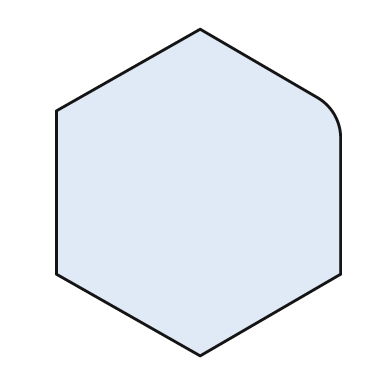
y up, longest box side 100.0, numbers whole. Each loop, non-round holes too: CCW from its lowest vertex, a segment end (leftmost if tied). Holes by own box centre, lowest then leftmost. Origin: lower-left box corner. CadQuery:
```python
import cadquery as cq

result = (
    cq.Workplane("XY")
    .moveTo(44.0, 0.0)
    .lineTo(87.0, 25.0)
    .lineTo(87.0, 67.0)
    .threePointArc((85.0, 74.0), (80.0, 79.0))
    .lineTo(44.0, 100.0)
    .lineTo(0.0, 75.0)
    .lineTo(0.0, 25.0)
    .close()
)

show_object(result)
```